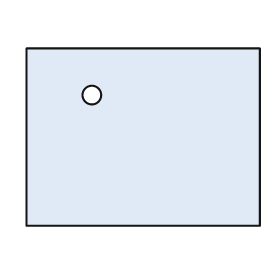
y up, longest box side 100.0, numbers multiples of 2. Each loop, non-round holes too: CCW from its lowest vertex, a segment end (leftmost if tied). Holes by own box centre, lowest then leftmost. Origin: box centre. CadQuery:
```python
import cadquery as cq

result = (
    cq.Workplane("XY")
    .moveTo(-50.0, -38.0)
    .lineTo(50.0, -38.0)
    .lineTo(50.0, 38.0)
    .lineTo(-50.0, 38.0)
    .close()
    .moveTo(-22.0, 18.0)
    .circle(4.0)
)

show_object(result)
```